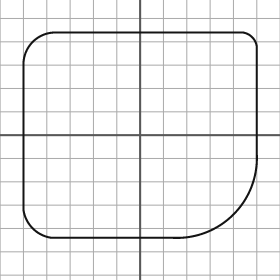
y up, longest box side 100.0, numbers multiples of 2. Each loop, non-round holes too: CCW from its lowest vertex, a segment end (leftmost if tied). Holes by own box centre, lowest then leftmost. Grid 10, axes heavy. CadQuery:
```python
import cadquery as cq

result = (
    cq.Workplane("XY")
    .moveTo(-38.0, -44.0)
    .lineTo(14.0, -44.0)
    .threePointArc((40.0, -34.0), (50.0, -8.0))
    .lineTo(50.0, 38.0)
    .threePointArc((48.0, 42.0), (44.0, 44.0))
    .lineTo(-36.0, 44.0)
    .threePointArc((-46.0, 40.0), (-50.0, 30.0))
    .lineTo(-50.0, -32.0)
    .threePointArc((-46.0, -40.0), (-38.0, -44.0))
    .close()
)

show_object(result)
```